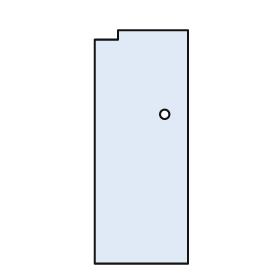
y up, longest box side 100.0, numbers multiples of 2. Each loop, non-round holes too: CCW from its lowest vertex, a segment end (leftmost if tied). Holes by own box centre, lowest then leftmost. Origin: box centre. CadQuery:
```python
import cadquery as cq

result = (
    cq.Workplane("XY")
    .moveTo(-20.0, -50.0)
    .lineTo(20.0, -50.0)
    .lineTo(20.0, 50.0)
    .lineTo(-10.0, 50.0)
    .lineTo(-10.0, 46.0)
    .lineTo(-20.0, 46.0)
    .close()
    .moveTo(10.0, 14.0)
    .circle(2.0)
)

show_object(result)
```